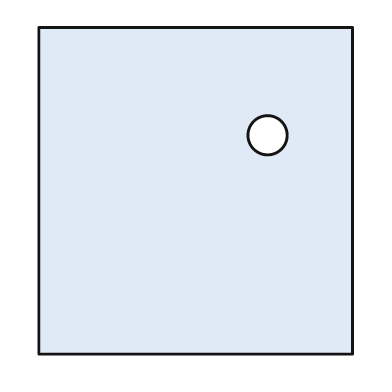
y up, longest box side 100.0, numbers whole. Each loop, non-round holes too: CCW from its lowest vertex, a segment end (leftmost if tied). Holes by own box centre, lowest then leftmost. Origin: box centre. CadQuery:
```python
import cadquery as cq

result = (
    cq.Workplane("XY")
    .moveTo(-48.0, -50.0)
    .lineTo(48.0, -50.0)
    .lineTo(48.0, 50.0)
    .lineTo(-48.0, 50.0)
    .close()
    .moveTo(22.0, 17.0)
    .circle(6.0)
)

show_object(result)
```